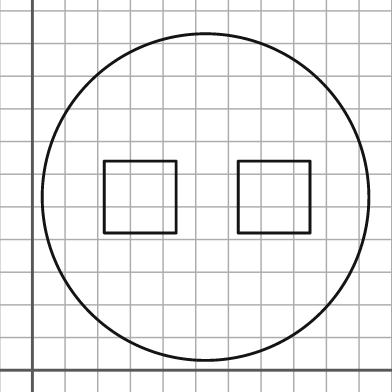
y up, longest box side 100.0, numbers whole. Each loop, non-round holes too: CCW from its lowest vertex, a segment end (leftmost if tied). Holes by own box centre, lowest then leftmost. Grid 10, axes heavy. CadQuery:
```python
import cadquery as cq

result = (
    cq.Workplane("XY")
    .moveTo(53.0, 53.0)
    .circle(50.0)
    .moveTo(22.0, 42.0)
    .lineTo(44.0, 42.0)
    .lineTo(44.0, 64.0)
    .lineTo(22.0, 64.0)
    .close()
    .moveTo(63.0, 42.0)
    .lineTo(85.0, 42.0)
    .lineTo(85.0, 64.0)
    .lineTo(63.0, 64.0)
    .close()
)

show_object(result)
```